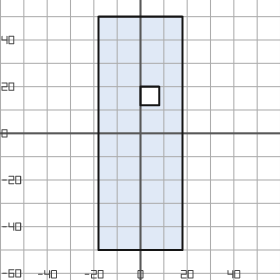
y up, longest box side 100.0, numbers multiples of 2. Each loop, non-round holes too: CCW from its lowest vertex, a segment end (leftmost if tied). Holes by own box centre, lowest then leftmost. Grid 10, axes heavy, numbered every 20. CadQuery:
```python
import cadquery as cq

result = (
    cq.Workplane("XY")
    .moveTo(-18.0, -50.0)
    .lineTo(18.0, -50.0)
    .lineTo(18.0, 50.0)
    .lineTo(-18.0, 50.0)
    .close()
    .moveTo(0.0, 12.0)
    .lineTo(8.0, 12.0)
    .lineTo(8.0, 20.0)
    .lineTo(0.0, 20.0)
    .close()
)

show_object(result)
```